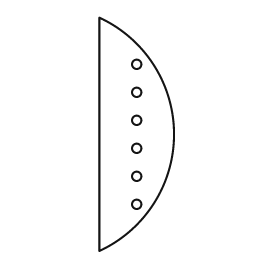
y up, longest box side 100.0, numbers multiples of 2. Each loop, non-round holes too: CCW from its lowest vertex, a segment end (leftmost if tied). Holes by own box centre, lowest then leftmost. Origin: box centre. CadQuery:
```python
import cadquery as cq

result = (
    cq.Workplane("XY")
    .moveTo(-16.0, -50.0)
    .threePointArc((16.0, 0.0), (-16.0, 50.0))
    .close()
    .moveTo(0.0, -30.0)
    .circle(2.0)
    .moveTo(0.0, -18.0)
    .circle(2.0)
    .moveTo(0.0, -6.0)
    .circle(2.0)
    .moveTo(0.0, 6.0)
    .circle(2.0)
    .moveTo(0.0, 18.0)
    .circle(2.0)
    .moveTo(0.0, 30.0)
    .circle(2.0)
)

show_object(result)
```